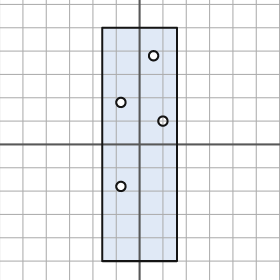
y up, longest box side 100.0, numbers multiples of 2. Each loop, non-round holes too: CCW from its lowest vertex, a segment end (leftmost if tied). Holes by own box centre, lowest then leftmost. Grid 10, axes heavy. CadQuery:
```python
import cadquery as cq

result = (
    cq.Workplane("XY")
    .moveTo(-16.0, -50.0)
    .lineTo(16.0, -50.0)
    .lineTo(16.0, 50.0)
    .lineTo(-16.0, 50.0)
    .close()
    .moveTo(-8.0, -18.0)
    .circle(2.0)
    .moveTo(10.0, 10.0)
    .circle(2.0)
    .moveTo(-8.0, 18.0)
    .circle(2.0)
    .moveTo(6.0, 38.0)
    .circle(2.0)
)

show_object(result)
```